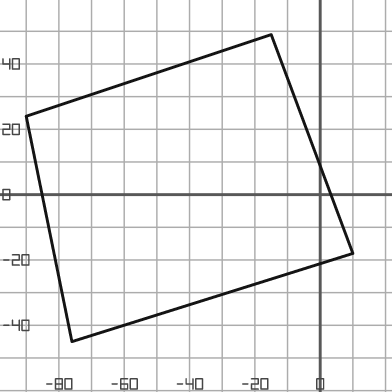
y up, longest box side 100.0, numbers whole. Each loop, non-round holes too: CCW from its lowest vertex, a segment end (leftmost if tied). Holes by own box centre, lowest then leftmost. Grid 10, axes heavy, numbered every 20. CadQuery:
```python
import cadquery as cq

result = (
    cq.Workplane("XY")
    .moveTo(-76.0, -45.0)
    .lineTo(10.0, -18.0)
    .lineTo(-15.0, 49.0)
    .lineTo(-90.0, 24.0)
    .close()
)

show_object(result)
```